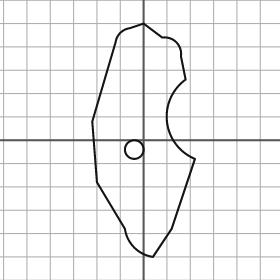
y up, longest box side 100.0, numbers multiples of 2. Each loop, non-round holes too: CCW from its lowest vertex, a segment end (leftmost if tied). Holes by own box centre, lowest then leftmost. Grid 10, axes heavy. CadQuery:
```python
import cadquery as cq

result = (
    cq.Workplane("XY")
    .moveTo(4.0, -50.0)
    .lineTo(12.0, -38.0)
    .lineTo(22.0, -8.0)
    .threePointArc((10.0, 8.0), (18.0, 26.0))
    .lineTo(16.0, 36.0)
    .threePointArc((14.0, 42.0), (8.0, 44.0))
    .lineTo(0.0, 50.0)
    .lineTo(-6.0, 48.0)
    .threePointArc((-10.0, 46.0), (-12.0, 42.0))
    .lineTo(-22.0, 8.0)
    .lineTo(-20.0, -18.0)
    .lineTo(-8.0, -38.0)
    .threePointArc((-4.0, -46.0), (4.0, -50.0))
    .close()
    .moveTo(-4.0, -4.0)
    .circle(4.0)
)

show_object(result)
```